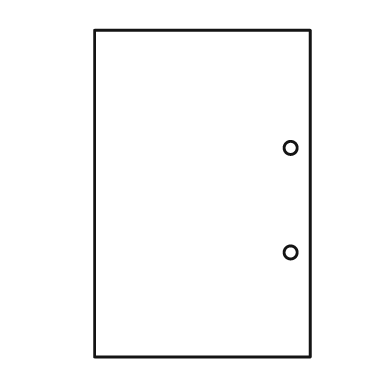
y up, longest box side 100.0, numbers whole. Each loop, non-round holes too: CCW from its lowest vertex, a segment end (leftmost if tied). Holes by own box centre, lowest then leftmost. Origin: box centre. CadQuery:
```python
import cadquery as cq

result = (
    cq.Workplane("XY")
    .moveTo(-33.0, -50.0)
    .lineTo(33.0, -50.0)
    .lineTo(33.0, 50.0)
    .lineTo(-33.0, 50.0)
    .close()
    .moveTo(27.0, -18.0)
    .circle(2.0)
    .moveTo(27.0, 14.0)
    .circle(2.0)
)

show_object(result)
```